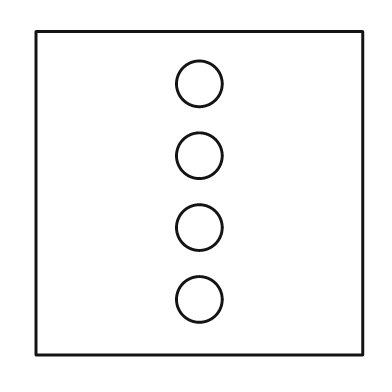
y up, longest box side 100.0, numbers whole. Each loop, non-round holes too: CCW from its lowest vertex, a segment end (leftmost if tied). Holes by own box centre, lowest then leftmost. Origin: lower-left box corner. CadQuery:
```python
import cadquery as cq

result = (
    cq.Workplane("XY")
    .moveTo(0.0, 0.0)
    .lineTo(100.0, 0.0)
    .lineTo(100.0, 99.0)
    .lineTo(0.0, 99.0)
    .close()
    .moveTo(50.0, 17.0)
    .circle(7.0)
    .moveTo(50.0, 39.0)
    .circle(7.0)
    .moveTo(50.0, 61.0)
    .circle(7.0)
    .moveTo(50.0, 83.0)
    .circle(7.0)
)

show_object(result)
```